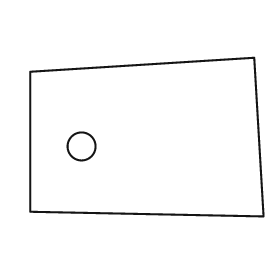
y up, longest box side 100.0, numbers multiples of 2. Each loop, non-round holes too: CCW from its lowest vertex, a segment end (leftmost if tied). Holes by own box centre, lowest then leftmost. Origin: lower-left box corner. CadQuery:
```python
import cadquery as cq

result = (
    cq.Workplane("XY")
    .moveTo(100.0, 0.0)
    .lineTo(96.0, 68.0)
    .lineTo(0.0, 62.0)
    .lineTo(0.0, 2.0)
    .close()
    .moveTo(22.0, 30.0)
    .circle(6.0)
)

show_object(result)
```